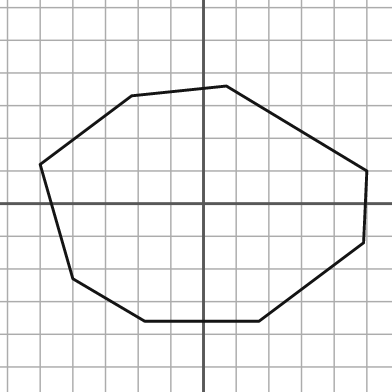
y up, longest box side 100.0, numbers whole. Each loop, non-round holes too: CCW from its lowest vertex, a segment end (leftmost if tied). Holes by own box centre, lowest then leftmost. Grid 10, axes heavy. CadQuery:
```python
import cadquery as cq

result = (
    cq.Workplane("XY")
    .moveTo(-18.0, -36.0)
    .lineTo(17.0, -36.0)
    .lineTo(49.0, -12.0)
    .lineTo(50.0, 10.0)
    .lineTo(7.0, 36.0)
    .lineTo(-22.0, 33.0)
    .lineTo(-50.0, 12.0)
    .lineTo(-40.0, -23.0)
    .close()
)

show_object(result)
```